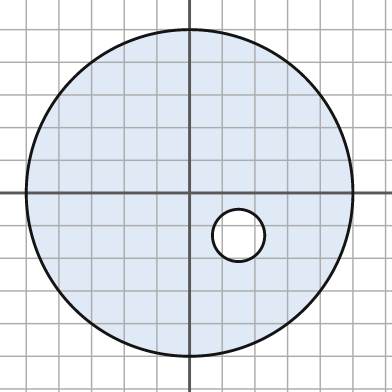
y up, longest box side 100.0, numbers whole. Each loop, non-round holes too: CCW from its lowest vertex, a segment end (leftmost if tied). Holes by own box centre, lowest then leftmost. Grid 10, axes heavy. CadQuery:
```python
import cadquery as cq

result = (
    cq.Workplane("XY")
    .moveTo(0.0, 0.0)
    .circle(50.0)
    .moveTo(15.0, -13.0)
    .circle(8.0)
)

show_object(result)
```